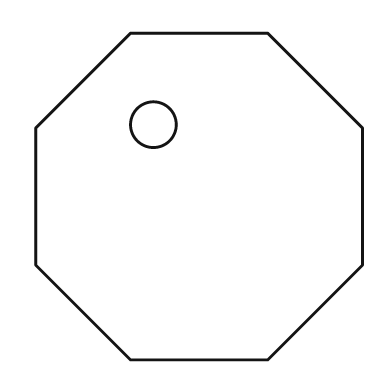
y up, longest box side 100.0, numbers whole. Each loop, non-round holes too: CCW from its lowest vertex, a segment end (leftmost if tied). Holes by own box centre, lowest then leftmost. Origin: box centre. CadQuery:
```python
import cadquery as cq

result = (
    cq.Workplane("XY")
    .moveTo(-21.0, -50.0)
    .lineTo(21.0, -50.0)
    .lineTo(50.0, -21.0)
    .lineTo(50.0, 21.0)
    .lineTo(21.0, 50.0)
    .lineTo(-21.0, 50.0)
    .lineTo(-50.0, 21.0)
    .lineTo(-50.0, -21.0)
    .close()
    .moveTo(-14.0, 22.0)
    .circle(7.0)
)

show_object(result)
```